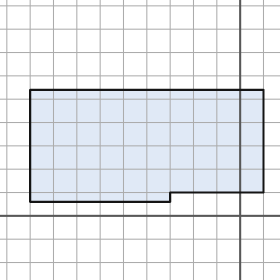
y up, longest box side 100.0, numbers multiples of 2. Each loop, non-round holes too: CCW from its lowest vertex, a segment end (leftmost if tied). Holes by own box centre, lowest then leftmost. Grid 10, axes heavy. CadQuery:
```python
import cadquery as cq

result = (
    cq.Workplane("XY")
    .moveTo(-90.0, 6.0)
    .lineTo(-30.0, 6.0)
    .lineTo(-30.0, 10.0)
    .lineTo(10.0, 10.0)
    .lineTo(10.0, 54.0)
    .lineTo(-90.0, 54.0)
    .close()
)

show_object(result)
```